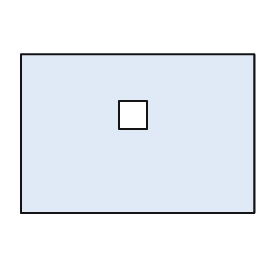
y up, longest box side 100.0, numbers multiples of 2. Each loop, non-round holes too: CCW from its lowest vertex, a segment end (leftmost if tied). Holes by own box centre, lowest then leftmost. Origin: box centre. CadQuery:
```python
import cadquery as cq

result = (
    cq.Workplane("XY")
    .moveTo(-50.0, -34.0)
    .lineTo(50.0, -34.0)
    .lineTo(50.0, 34.0)
    .lineTo(-50.0, 34.0)
    .close()
    .moveTo(-8.0, 2.0)
    .lineTo(4.0, 2.0)
    .lineTo(4.0, 14.0)
    .lineTo(-8.0, 14.0)
    .close()
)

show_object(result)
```